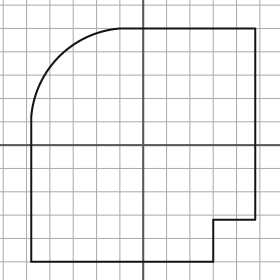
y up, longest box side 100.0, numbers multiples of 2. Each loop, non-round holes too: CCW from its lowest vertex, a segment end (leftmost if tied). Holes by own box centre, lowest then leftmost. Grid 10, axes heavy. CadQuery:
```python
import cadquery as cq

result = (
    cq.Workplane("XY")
    .moveTo(-48.0, -50.0)
    .lineTo(30.0, -50.0)
    .lineTo(30.0, -32.0)
    .lineTo(48.0, -32.0)
    .lineTo(48.0, 50.0)
    .lineTo(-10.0, 50.0)
    .threePointArc((-36.0, 38.0), (-48.0, 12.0))
    .close()
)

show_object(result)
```